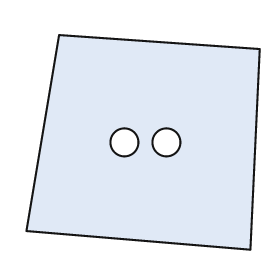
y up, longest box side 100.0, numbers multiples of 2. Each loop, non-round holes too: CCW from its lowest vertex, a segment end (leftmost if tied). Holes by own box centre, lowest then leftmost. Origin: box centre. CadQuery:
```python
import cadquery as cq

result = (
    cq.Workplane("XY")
    .moveTo(46.0, -46.0)
    .lineTo(50.0, 40.0)
    .lineTo(-36.0, 46.0)
    .lineTo(-50.0, -38.0)
    .close()
    .moveTo(-8.0, 0.0)
    .circle(6.0)
    .moveTo(10.0, 0.0)
    .circle(6.0)
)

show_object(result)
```